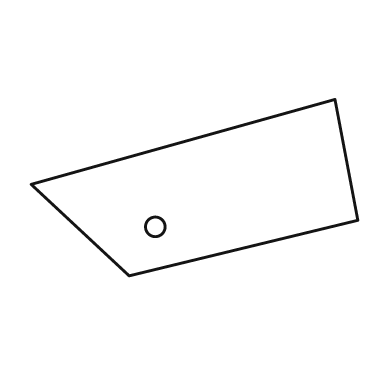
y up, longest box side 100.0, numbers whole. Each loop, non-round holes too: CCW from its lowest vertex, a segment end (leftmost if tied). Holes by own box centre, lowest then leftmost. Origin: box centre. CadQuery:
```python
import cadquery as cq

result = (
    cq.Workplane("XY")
    .moveTo(-20.0, -27.0)
    .lineTo(50.0, -10.0)
    .lineTo(43.0, 27.0)
    .lineTo(-50.0, 1.0)
    .close()
    .moveTo(-12.0, -12.0)
    .circle(3.0)
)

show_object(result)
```